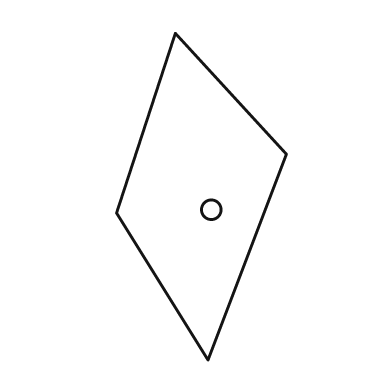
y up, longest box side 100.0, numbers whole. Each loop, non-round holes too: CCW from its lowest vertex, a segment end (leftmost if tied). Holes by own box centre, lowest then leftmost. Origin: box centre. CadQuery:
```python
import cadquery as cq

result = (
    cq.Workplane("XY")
    .moveTo(2.0, -50.0)
    .lineTo(26.0, 13.0)
    .lineTo(-8.0, 50.0)
    .lineTo(-26.0, -5.0)
    .close()
    .moveTo(3.0, -4.0)
    .circle(3.0)
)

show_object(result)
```